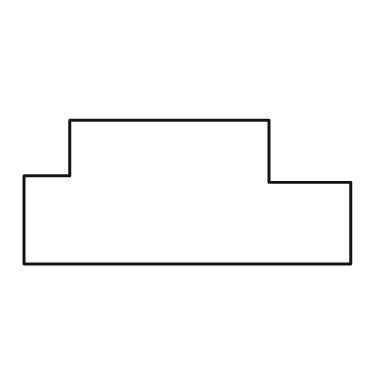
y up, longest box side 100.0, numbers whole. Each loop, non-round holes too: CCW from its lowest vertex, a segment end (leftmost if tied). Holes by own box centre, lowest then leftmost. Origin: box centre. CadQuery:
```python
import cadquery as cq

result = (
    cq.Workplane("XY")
    .moveTo(-50.0, -22.0)
    .lineTo(50.0, -22.0)
    .lineTo(50.0, 3.0)
    .lineTo(25.0, 3.0)
    .lineTo(25.0, 22.0)
    .lineTo(-36.0, 22.0)
    .lineTo(-36.0, 5.0)
    .lineTo(-50.0, 5.0)
    .close()
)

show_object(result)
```